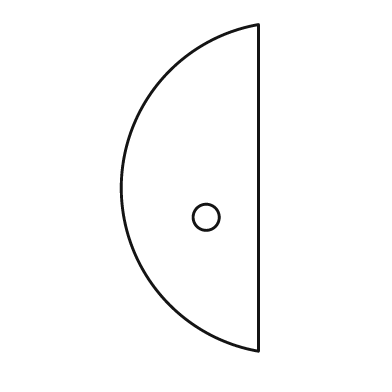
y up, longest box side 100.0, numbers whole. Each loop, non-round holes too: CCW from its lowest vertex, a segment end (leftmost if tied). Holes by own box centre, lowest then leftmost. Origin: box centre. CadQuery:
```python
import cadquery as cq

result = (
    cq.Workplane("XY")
    .moveTo(21.0, -50.0)
    .lineTo(21.0, 50.0)
    .threePointArc((-21.0, 0.0), (21.0, -50.0))
    .close()
    .moveTo(5.0, -9.0)
    .circle(4.0)
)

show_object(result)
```